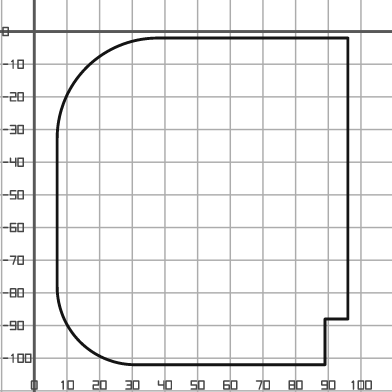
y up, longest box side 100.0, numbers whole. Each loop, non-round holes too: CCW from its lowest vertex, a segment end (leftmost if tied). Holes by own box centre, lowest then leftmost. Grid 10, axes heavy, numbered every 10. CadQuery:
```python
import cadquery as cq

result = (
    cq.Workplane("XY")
    .moveTo(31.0, -102.0)
    .lineTo(89.0, -102.0)
    .lineTo(89.0, -88.0)
    .lineTo(96.0, -88.0)
    .lineTo(96.0, -2.0)
    .lineTo(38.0, -2.0)
    .threePointArc((16.0, -11.0), (7.0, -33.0))
    .lineTo(7.0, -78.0)
    .threePointArc((14.0, -95.0), (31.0, -102.0))
    .close()
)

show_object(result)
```